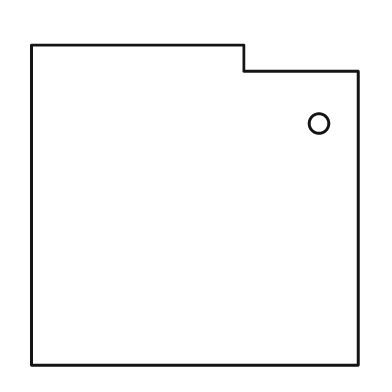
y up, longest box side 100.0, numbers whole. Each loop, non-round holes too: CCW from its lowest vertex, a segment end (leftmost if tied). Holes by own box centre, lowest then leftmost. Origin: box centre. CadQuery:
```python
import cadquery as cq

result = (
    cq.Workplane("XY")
    .moveTo(-50.0, -49.0)
    .lineTo(50.0, -49.0)
    .lineTo(50.0, 41.0)
    .lineTo(15.0, 41.0)
    .lineTo(15.0, 49.0)
    .lineTo(-50.0, 49.0)
    .close()
    .moveTo(38.0, 25.0)
    .circle(3.0)
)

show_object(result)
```